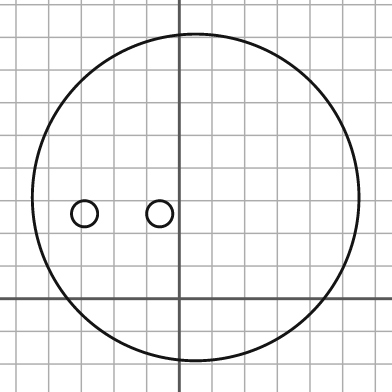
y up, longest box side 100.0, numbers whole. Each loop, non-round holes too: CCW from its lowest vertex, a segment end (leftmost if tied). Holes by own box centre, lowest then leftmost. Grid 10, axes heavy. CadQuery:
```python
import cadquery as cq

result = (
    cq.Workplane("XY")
    .moveTo(5.0, 31.0)
    .circle(50.0)
    .moveTo(-29.0, 26.0)
    .circle(4.0)
    .moveTo(-6.0, 26.0)
    .circle(4.0)
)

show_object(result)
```